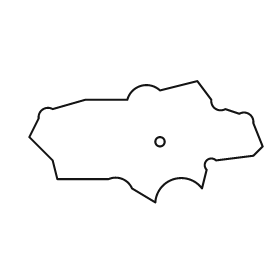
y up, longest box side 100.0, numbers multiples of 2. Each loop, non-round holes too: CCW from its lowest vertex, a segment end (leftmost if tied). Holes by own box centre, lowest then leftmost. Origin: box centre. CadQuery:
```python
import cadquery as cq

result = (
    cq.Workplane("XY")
    .moveTo(4.0, -26.0)
    .threePointArc((12.0, -16.0), (24.0, -20.0))
    .lineTo(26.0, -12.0)
    .threePointArc((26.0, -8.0), (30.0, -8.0))
    .lineTo(46.0, -6.0)
    .lineTo(50.0, -2.0)
    .lineTo(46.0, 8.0)
    .threePointArc((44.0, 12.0), (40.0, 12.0))
    .lineTo(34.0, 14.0)
    .threePointArc((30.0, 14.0), (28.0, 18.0))
    .lineTo(22.0, 26.0)
    .lineTo(6.0, 22.0)
    .threePointArc((-2.0, 24.0), (-8.0, 18.0))
    .lineTo(-26.0, 18.0)
    .lineTo(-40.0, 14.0)
    .threePointArc((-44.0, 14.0), (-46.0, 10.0))
    .lineTo(-50.0, 2.0)
    .lineTo(-40.0, -8.0)
    .lineTo(-38.0, -16.0)
    .lineTo(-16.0, -16.0)
    .threePointArc((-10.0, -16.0), (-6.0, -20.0))
    .close()
    .moveTo(6.0, 0.0)
    .circle(2.0)
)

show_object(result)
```